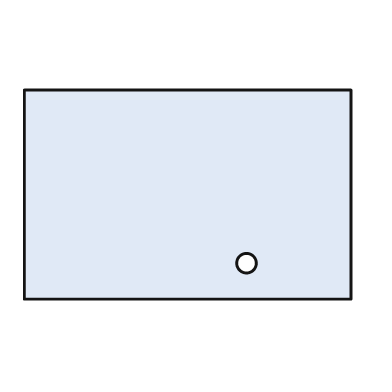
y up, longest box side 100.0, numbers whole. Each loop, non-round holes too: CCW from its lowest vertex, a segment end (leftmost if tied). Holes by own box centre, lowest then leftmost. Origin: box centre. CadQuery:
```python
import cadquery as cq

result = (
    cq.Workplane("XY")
    .moveTo(-50.0, -32.0)
    .lineTo(50.0, -32.0)
    .lineTo(50.0, 32.0)
    .lineTo(-50.0, 32.0)
    .close()
    .moveTo(18.0, -21.0)
    .circle(3.0)
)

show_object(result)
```